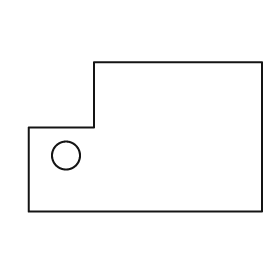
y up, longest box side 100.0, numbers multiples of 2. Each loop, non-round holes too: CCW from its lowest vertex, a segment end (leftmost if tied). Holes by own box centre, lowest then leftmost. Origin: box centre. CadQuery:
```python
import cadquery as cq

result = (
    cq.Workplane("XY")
    .moveTo(-50.0, -32.0)
    .lineTo(50.0, -32.0)
    .lineTo(50.0, 32.0)
    .lineTo(-22.0, 32.0)
    .lineTo(-22.0, 4.0)
    .lineTo(-50.0, 4.0)
    .close()
    .moveTo(-34.0, -8.0)
    .circle(6.0)
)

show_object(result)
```